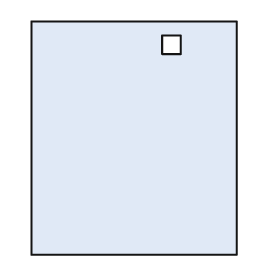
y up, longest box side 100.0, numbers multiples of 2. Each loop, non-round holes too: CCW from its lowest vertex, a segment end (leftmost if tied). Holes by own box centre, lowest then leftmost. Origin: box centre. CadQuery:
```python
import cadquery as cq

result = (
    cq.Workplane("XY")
    .moveTo(-44.0, -50.0)
    .lineTo(44.0, -50.0)
    .lineTo(44.0, 50.0)
    .lineTo(-44.0, 50.0)
    .close()
    .moveTo(12.0, 36.0)
    .lineTo(20.0, 36.0)
    .lineTo(20.0, 44.0)
    .lineTo(12.0, 44.0)
    .close()
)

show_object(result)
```